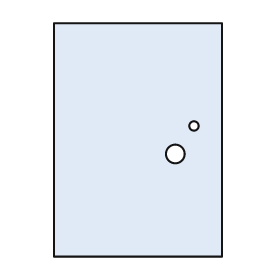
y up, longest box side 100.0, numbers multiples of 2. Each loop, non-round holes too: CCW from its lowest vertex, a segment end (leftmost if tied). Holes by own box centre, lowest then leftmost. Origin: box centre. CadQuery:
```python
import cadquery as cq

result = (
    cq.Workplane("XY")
    .moveTo(-36.0, -50.0)
    .lineTo(36.0, -50.0)
    .lineTo(36.0, 50.0)
    .lineTo(-36.0, 50.0)
    .close()
    .moveTo(16.0, -6.0)
    .circle(4.0)
    .moveTo(24.0, 6.0)
    .circle(2.0)
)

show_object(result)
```